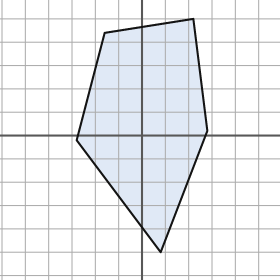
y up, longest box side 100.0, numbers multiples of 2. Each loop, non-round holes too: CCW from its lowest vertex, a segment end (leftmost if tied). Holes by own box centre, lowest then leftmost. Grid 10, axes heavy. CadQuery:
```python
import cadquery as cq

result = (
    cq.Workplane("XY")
    .moveTo(8.0, -50.0)
    .lineTo(28.0, 2.0)
    .lineTo(22.0, 50.0)
    .lineTo(-16.0, 44.0)
    .lineTo(-28.0, -2.0)
    .close()
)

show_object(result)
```